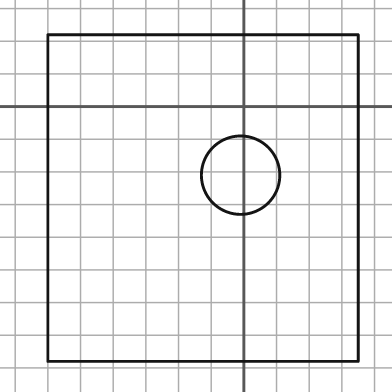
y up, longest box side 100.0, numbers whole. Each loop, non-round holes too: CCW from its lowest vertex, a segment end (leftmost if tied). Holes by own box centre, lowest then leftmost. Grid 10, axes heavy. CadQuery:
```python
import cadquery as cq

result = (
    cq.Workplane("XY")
    .moveTo(-60.0, -78.0)
    .lineTo(35.0, -78.0)
    .lineTo(35.0, 22.0)
    .lineTo(-60.0, 22.0)
    .close()
    .moveTo(-1.0, -21.0)
    .circle(12.0)
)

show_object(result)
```